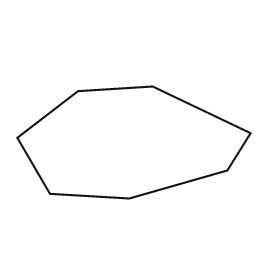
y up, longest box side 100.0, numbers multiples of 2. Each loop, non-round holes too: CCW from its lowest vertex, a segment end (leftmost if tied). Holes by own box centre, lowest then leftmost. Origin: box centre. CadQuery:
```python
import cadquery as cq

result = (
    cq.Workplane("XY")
    .moveTo(-2.0, -24.0)
    .lineTo(40.0, -12.0)
    .lineTo(50.0, 4.0)
    .lineTo(8.0, 24.0)
    .lineTo(-24.0, 22.0)
    .lineTo(-50.0, 2.0)
    .lineTo(-36.0, -22.0)
    .close()
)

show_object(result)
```